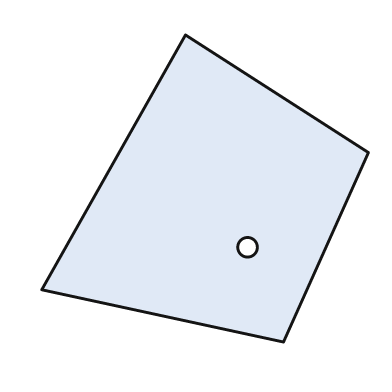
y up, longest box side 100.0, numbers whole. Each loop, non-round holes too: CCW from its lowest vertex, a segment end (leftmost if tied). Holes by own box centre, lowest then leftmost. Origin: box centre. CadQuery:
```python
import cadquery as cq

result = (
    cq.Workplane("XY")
    .moveTo(24.0, -47.0)
    .lineTo(50.0, 11.0)
    .lineTo(-6.0, 47.0)
    .lineTo(-50.0, -31.0)
    .close()
    .moveTo(13.0, -18.0)
    .circle(3.0)
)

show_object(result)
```